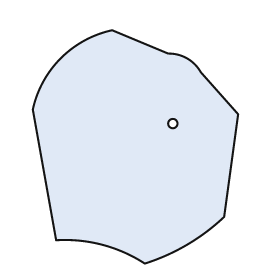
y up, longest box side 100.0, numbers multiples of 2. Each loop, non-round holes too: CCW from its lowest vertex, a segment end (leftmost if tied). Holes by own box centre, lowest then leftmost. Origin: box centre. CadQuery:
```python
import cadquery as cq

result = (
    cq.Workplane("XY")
    .moveTo(4.0, -50.0)
    .threePointArc((22.0, -42.0), (38.0, -30.0))
    .lineTo(44.0, 14.0)
    .lineTo(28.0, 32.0)
    .threePointArc((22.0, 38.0), (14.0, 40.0))
    .lineTo(-10.0, 50.0)
    .threePointArc((-32.0, 38.0), (-44.0, 16.0))
    .lineTo(-34.0, -40.0)
    .threePointArc((-14.0, -42.0), (4.0, -50.0))
    .close()
    .moveTo(16.0, 10.0)
    .circle(2.0)
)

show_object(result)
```